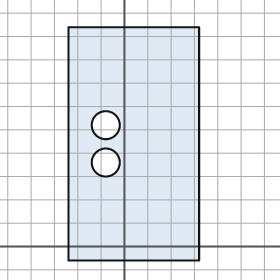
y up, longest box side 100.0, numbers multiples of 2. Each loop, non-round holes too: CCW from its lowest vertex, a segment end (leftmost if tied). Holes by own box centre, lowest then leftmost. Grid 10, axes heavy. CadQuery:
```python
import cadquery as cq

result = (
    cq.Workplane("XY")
    .moveTo(-24.0, -6.0)
    .lineTo(32.0, -6.0)
    .lineTo(32.0, 94.0)
    .lineTo(-24.0, 94.0)
    .close()
    .moveTo(-8.0, 36.0)
    .circle(6.0)
    .moveTo(-8.0, 52.0)
    .circle(6.0)
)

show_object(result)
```